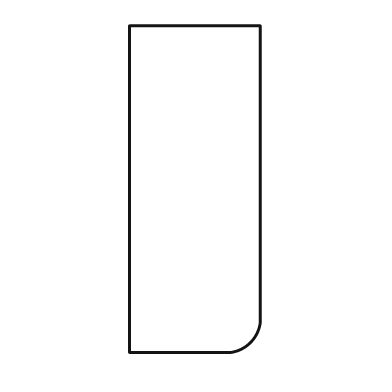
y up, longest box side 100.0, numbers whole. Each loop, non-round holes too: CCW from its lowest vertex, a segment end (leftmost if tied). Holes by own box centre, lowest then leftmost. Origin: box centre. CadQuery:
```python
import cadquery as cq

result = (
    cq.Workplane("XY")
    .moveTo(-20.0, -50.0)
    .lineTo(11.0, -50.0)
    .threePointArc((17.0, -47.0), (20.0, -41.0))
    .lineTo(20.0, 50.0)
    .lineTo(-20.0, 50.0)
    .close()
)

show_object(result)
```